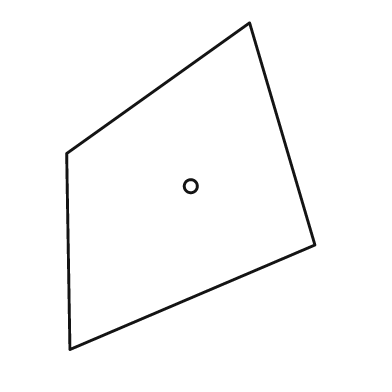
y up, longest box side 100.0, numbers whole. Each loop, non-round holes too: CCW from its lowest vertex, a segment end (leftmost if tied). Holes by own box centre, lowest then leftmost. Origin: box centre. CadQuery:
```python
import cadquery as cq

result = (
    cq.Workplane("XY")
    .moveTo(-37.0, -50.0)
    .lineTo(38.0, -18.0)
    .lineTo(18.0, 50.0)
    .lineTo(-38.0, 10.0)
    .close()
    .moveTo(0.0, 0.0)
    .circle(2.0)
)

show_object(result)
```